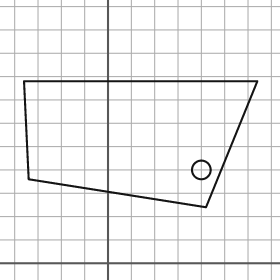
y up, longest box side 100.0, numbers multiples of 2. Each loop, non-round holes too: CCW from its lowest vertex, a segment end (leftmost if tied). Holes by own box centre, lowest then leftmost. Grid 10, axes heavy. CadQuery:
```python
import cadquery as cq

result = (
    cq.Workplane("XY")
    .moveTo(42.0, 24.0)
    .lineTo(64.0, 78.0)
    .lineTo(-36.0, 78.0)
    .lineTo(-34.0, 36.0)
    .close()
    .moveTo(40.0, 40.0)
    .circle(4.0)
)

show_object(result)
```